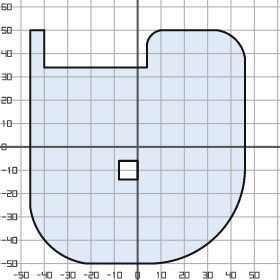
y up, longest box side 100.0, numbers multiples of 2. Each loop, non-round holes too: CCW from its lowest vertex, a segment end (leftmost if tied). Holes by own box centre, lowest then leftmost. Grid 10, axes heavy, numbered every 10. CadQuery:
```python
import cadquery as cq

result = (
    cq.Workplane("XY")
    .moveTo(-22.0, -50.0)
    .lineTo(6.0, -50.0)
    .threePointArc((34.0, -38.0), (46.0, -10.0))
    .lineTo(46.0, 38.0)
    .threePointArc((42.0, 46.0), (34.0, 50.0))
    .lineTo(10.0, 50.0)
    .threePointArc((6.0, 48.0), (4.0, 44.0))
    .lineTo(4.0, 34.0)
    .lineTo(-40.0, 34.0)
    .lineTo(-40.0, 50.0)
    .lineTo(-46.0, 50.0)
    .lineTo(-46.0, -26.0)
    .threePointArc((-38.0, -42.0), (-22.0, -50.0))
    .close()
    .moveTo(-8.0, -14.0)
    .lineTo(0.0, -14.0)
    .lineTo(0.0, -6.0)
    .lineTo(-8.0, -6.0)
    .close()
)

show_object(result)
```